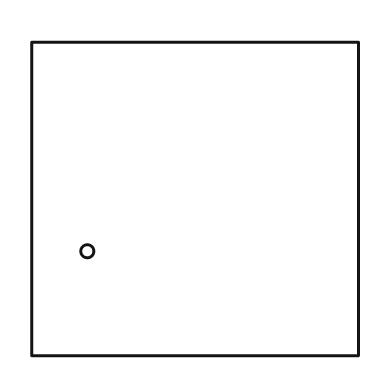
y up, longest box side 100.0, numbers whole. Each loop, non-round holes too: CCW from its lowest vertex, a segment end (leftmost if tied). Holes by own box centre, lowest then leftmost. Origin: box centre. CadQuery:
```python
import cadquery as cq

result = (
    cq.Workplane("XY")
    .moveTo(-50.0, -48.0)
    .lineTo(50.0, -48.0)
    .lineTo(50.0, 48.0)
    .lineTo(-50.0, 48.0)
    .close()
    .moveTo(-33.0, -16.0)
    .circle(2.0)
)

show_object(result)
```